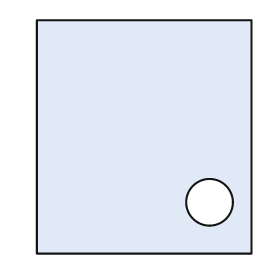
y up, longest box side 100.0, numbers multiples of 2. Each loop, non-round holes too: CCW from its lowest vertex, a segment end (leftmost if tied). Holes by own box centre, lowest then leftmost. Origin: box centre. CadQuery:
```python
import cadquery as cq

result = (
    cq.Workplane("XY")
    .moveTo(-46.0, -50.0)
    .lineTo(46.0, -50.0)
    .lineTo(46.0, 50.0)
    .lineTo(-46.0, 50.0)
    .close()
    .moveTo(28.0, -28.0)
    .circle(10.0)
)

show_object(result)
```